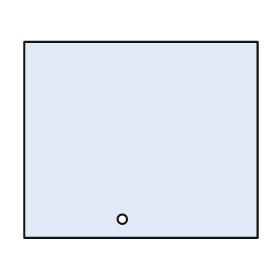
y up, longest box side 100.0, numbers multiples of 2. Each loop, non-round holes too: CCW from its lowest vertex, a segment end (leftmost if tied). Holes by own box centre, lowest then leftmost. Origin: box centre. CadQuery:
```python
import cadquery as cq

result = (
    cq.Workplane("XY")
    .moveTo(-50.0, -42.0)
    .lineTo(50.0, -42.0)
    .lineTo(50.0, 42.0)
    .lineTo(-50.0, 42.0)
    .close()
    .moveTo(-8.0, -34.0)
    .circle(2.0)
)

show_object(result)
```